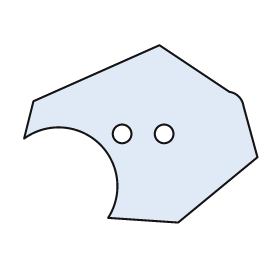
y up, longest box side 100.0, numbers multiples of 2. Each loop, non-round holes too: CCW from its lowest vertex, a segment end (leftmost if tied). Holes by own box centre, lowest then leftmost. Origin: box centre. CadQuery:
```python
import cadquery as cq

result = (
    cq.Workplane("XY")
    .moveTo(16.0, -38.0)
    .lineTo(50.0, -10.0)
    .lineTo(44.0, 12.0)
    .threePointArc((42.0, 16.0), (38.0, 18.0))
    .lineTo(8.0, 38.0)
    .lineTo(-46.0, 14.0)
    .lineTo(-50.0, -2.0)
    .threePointArc((-18.0, -4.0), (-14.0, -36.0))
    .close()
    .moveTo(-8.0, 0.0)
    .circle(4.0)
    .moveTo(10.0, 0.0)
    .circle(4.0)
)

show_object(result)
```